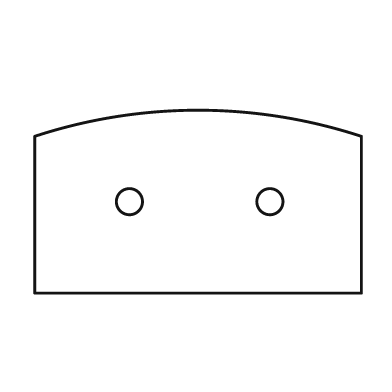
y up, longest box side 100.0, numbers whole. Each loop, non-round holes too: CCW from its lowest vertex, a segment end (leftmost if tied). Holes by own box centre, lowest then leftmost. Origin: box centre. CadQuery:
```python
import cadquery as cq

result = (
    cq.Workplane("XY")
    .moveTo(-50.0, -28.0)
    .lineTo(50.0, -28.0)
    .lineTo(50.0, 20.0)
    .threePointArc((0.0, 28.0), (-50.0, 20.0))
    .close()
    .moveTo(-21.0, 0.0)
    .circle(4.0)
    .moveTo(22.0, 0.0)
    .circle(4.0)
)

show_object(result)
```